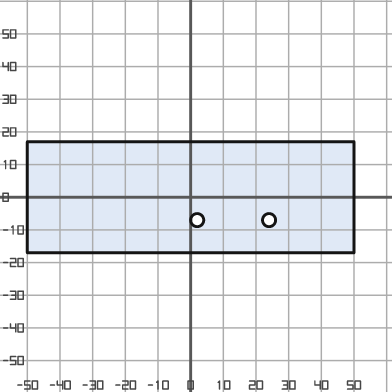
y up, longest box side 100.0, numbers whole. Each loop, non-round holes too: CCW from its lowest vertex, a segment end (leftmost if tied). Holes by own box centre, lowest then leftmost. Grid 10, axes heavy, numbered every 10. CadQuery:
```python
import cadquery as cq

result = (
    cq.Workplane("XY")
    .moveTo(-50.0, -17.0)
    .lineTo(50.0, -17.0)
    .lineTo(50.0, 17.0)
    .lineTo(-50.0, 17.0)
    .close()
    .moveTo(2.0, -7.0)
    .circle(2.0)
    .moveTo(24.0, -7.0)
    .circle(2.0)
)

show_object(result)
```